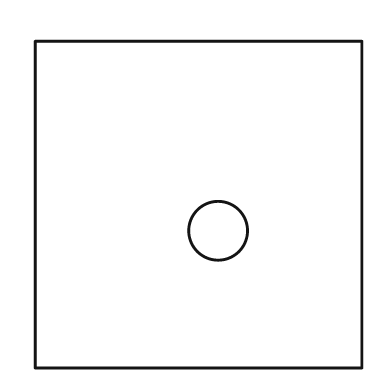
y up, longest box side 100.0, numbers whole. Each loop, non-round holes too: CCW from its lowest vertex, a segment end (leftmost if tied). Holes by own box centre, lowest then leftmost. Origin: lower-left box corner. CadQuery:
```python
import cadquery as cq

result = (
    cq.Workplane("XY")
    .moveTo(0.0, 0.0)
    .lineTo(100.0, 0.0)
    .lineTo(100.0, 100.0)
    .lineTo(0.0, 100.0)
    .close()
    .moveTo(56.0, 42.0)
    .circle(9.0)
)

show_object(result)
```